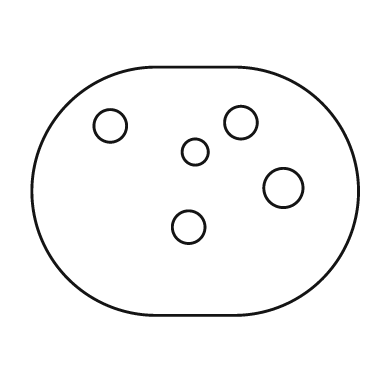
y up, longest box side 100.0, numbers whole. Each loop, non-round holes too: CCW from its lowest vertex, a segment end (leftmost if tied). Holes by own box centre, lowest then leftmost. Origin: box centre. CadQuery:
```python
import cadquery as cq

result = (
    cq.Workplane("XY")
    .moveTo(-12.0, -38.0)
    .lineTo(12.0, -38.0)
    .threePointArc((50.0, 0.0), (12.0, 38.0))
    .lineTo(-12.0, 38.0)
    .threePointArc((-50.0, 0.0), (-12.0, -38.0))
    .close()
    .moveTo(-2.0, -11.0)
    .circle(5.0)
    .moveTo(27.0, 1.0)
    .circle(6.0)
    .moveTo(0.0, 12.0)
    .circle(4.0)
    .moveTo(-26.0, 20.0)
    .circle(5.0)
    .moveTo(14.0, 21.0)
    .circle(5.0)
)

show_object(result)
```